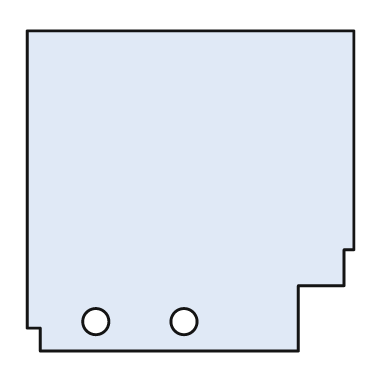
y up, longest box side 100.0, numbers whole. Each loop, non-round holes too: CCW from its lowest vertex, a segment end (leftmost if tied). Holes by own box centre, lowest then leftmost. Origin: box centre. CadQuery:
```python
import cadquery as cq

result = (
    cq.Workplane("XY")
    .moveTo(-46.0, -49.0)
    .lineTo(33.0, -49.0)
    .lineTo(33.0, -29.0)
    .lineTo(47.0, -29.0)
    .lineTo(47.0, -18.0)
    .lineTo(50.0, -18.0)
    .lineTo(50.0, 49.0)
    .lineTo(-50.0, 49.0)
    .lineTo(-50.0, -42.0)
    .lineTo(-46.0, -42.0)
    .close()
    .moveTo(-29.0, -40.0)
    .circle(4.0)
    .moveTo(-2.0, -40.0)
    .circle(4.0)
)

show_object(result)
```